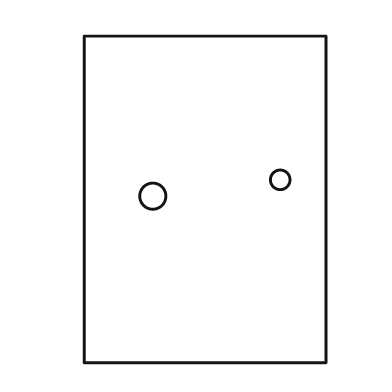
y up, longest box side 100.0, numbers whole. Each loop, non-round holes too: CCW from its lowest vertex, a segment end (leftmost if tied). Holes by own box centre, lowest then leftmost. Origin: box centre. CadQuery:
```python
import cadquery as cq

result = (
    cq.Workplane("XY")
    .moveTo(-37.0, -50.0)
    .lineTo(37.0, -50.0)
    .lineTo(37.0, 50.0)
    .lineTo(-37.0, 50.0)
    .close()
    .moveTo(-16.0, 1.0)
    .circle(4.0)
    .moveTo(23.0, 6.0)
    .circle(3.0)
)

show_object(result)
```